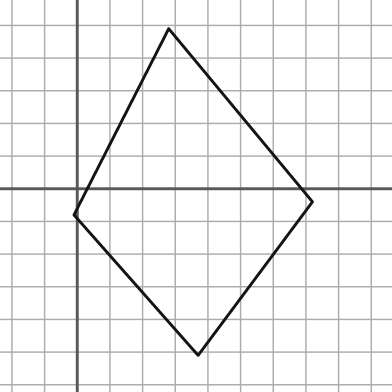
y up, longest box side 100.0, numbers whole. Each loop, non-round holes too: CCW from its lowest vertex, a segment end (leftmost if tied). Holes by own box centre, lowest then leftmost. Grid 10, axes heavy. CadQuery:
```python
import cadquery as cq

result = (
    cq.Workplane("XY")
    .moveTo(37.0, -51.0)
    .lineTo(72.0, -4.0)
    .lineTo(28.0, 49.0)
    .lineTo(-1.0, -8.0)
    .close()
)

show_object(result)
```